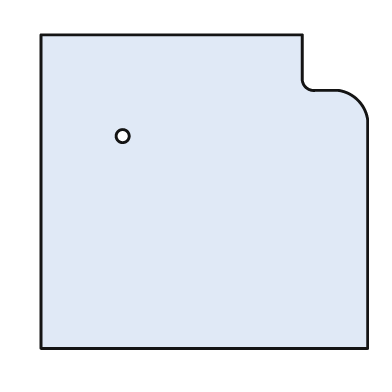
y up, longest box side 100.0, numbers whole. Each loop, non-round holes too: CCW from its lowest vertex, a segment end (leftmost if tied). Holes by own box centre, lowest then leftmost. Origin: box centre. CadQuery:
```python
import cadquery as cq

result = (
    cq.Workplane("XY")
    .moveTo(-50.0, -48.0)
    .lineTo(50.0, -48.0)
    .lineTo(50.0, 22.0)
    .threePointArc((47.0, 28.0), (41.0, 31.0))
    .lineTo(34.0, 31.0)
    .threePointArc((31.0, 32.0), (30.0, 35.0))
    .lineTo(30.0, 48.0)
    .lineTo(-50.0, 48.0)
    .close()
    .moveTo(-25.0, 17.0)
    .circle(2.0)
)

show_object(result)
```